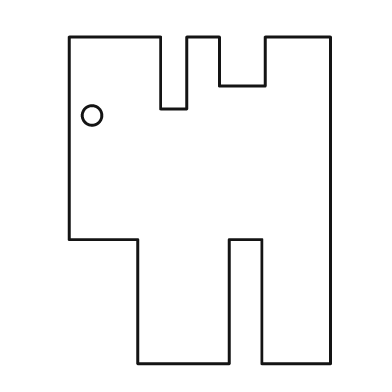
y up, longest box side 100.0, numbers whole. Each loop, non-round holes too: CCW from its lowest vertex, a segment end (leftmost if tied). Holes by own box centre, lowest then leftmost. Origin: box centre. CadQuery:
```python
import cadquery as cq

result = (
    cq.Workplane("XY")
    .moveTo(-19.0, -50.0)
    .lineTo(9.0, -50.0)
    .lineTo(9.0, -12.0)
    .lineTo(19.0, -12.0)
    .lineTo(19.0, -50.0)
    .lineTo(40.0, -50.0)
    .lineTo(40.0, 50.0)
    .lineTo(20.0, 50.0)
    .lineTo(20.0, 35.0)
    .lineTo(6.0, 35.0)
    .lineTo(6.0, 50.0)
    .lineTo(-4.0, 50.0)
    .lineTo(-4.0, 28.0)
    .lineTo(-12.0, 28.0)
    .lineTo(-12.0, 50.0)
    .lineTo(-40.0, 50.0)
    .lineTo(-40.0, -12.0)
    .lineTo(-19.0, -12.0)
    .close()
    .moveTo(-33.0, 26.0)
    .circle(3.0)
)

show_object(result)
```